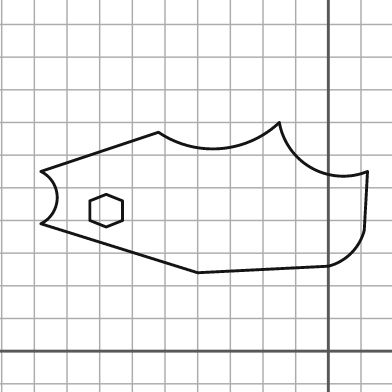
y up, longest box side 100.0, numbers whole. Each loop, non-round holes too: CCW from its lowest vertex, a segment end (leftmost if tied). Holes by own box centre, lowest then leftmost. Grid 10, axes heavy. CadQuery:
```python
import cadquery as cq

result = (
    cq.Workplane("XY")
    .moveTo(-40.0, 24.0)
    .lineTo(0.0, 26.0)
    .threePointArc((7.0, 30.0), (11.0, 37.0))
    .lineTo(12.0, 55.0)
    .threePointArc((-5.0, 56.0), (-15.0, 70.0))
    .threePointArc((-33.0, 62.0), (-52.0, 67.0))
    .lineTo(-88.0, 55.0)
    .threePointArc((-83.0, 47.0), (-88.0, 39.0))
    .close()
    .moveTo(-68.0, 38.0)
    .lineTo(-63.0, 40.0)
    .lineTo(-63.0, 46.0)
    .lineTo(-68.0, 48.0)
    .lineTo(-73.0, 46.0)
    .lineTo(-73.0, 40.0)
    .close()
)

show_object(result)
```